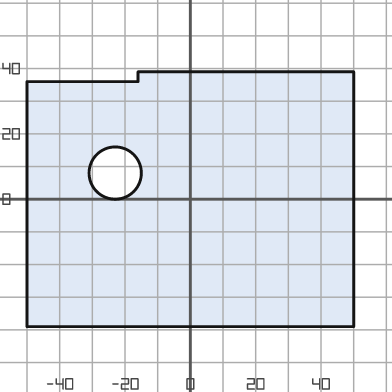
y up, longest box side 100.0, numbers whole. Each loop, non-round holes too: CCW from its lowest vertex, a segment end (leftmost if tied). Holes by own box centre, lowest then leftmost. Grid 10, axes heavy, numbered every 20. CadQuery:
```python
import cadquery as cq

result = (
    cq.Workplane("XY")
    .moveTo(-50.0, -39.0)
    .lineTo(50.0, -39.0)
    .lineTo(50.0, 39.0)
    .lineTo(-16.0, 39.0)
    .lineTo(-16.0, 36.0)
    .lineTo(-50.0, 36.0)
    .close()
    .moveTo(-23.0, 8.0)
    .circle(8.0)
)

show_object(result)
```